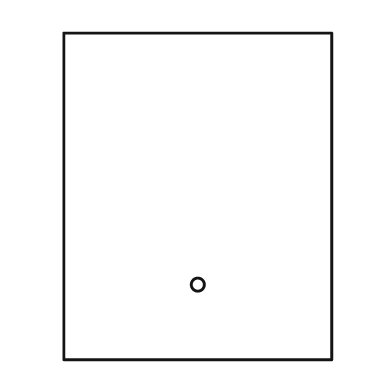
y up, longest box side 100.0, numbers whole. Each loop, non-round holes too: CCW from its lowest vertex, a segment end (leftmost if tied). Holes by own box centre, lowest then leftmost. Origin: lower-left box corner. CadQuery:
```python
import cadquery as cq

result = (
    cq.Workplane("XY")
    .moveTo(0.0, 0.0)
    .lineTo(82.0, 0.0)
    .lineTo(82.0, 100.0)
    .lineTo(0.0, 100.0)
    .close()
    .moveTo(41.0, 23.0)
    .circle(2.0)
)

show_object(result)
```